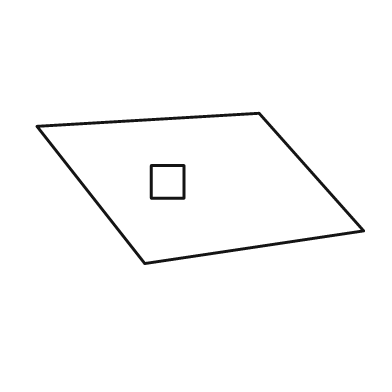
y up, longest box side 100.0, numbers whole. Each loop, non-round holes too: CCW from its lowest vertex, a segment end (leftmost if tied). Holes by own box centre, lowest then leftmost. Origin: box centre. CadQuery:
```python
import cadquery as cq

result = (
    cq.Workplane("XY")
    .moveTo(-17.0, -23.0)
    .lineTo(50.0, -13.0)
    .lineTo(18.0, 23.0)
    .lineTo(-50.0, 19.0)
    .close()
    .moveTo(-15.0, -3.0)
    .lineTo(-5.0, -3.0)
    .lineTo(-5.0, 7.0)
    .lineTo(-15.0, 7.0)
    .close()
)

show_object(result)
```